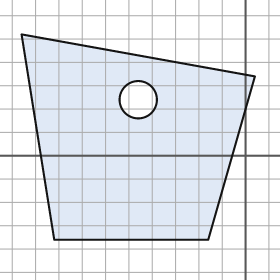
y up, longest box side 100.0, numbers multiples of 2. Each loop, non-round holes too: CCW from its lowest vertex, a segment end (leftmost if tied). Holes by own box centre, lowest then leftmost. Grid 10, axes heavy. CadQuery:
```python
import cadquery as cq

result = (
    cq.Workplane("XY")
    .moveTo(-82.0, -36.0)
    .lineTo(-16.0, -36.0)
    .lineTo(4.0, 34.0)
    .lineTo(-96.0, 52.0)
    .close()
    .moveTo(-46.0, 24.0)
    .circle(8.0)
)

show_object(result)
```